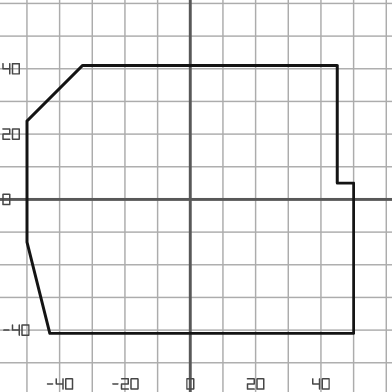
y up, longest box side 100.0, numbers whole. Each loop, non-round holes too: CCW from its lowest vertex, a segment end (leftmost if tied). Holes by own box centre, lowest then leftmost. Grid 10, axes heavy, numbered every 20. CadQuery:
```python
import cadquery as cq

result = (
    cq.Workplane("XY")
    .moveTo(-43.0, -41.0)
    .lineTo(50.0, -41.0)
    .lineTo(50.0, 5.0)
    .lineTo(45.0, 5.0)
    .lineTo(45.0, 41.0)
    .lineTo(-33.0, 41.0)
    .lineTo(-50.0, 24.0)
    .lineTo(-50.0, -13.0)
    .close()
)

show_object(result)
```